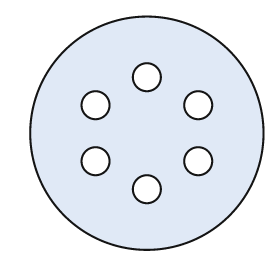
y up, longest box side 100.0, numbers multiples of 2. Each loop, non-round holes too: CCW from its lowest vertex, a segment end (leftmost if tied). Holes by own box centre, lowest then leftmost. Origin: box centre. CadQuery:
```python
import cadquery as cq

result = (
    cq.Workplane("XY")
    .moveTo(0.0, 0.0)
    .circle(50.0)
    .moveTo(0.0, -24.0)
    .circle(6.0)
    .moveTo(-22.0, -12.0)
    .circle(6.0)
    .moveTo(22.0, -12.0)
    .circle(6.0)
    .moveTo(-22.0, 12.0)
    .circle(6.0)
    .moveTo(22.0, 12.0)
    .circle(6.0)
    .moveTo(0.0, 24.0)
    .circle(6.0)
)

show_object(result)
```